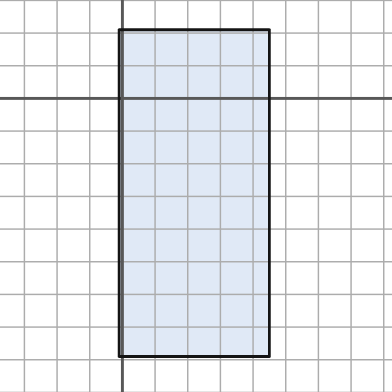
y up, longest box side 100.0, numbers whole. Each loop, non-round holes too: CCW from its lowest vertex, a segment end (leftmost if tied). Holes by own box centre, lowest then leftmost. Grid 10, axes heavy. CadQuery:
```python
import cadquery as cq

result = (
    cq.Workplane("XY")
    .moveTo(-1.0, -79.0)
    .lineTo(45.0, -79.0)
    .lineTo(45.0, 21.0)
    .lineTo(-1.0, 21.0)
    .close()
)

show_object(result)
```